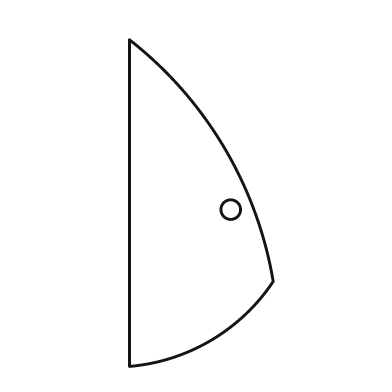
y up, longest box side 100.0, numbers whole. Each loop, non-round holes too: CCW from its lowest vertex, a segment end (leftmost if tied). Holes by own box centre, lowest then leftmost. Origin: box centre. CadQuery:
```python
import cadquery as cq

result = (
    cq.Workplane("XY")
    .moveTo(-22.0, -50.0)
    .threePointArc((3.0, -42.0), (22.0, -24.0))
    .threePointArc((7.0, 17.0), (-22.0, 50.0))
    .close()
    .moveTo(9.0, -2.0)
    .circle(3.0)
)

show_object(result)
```